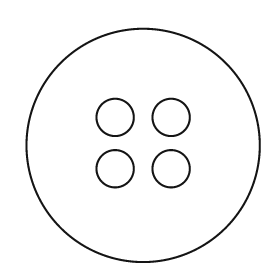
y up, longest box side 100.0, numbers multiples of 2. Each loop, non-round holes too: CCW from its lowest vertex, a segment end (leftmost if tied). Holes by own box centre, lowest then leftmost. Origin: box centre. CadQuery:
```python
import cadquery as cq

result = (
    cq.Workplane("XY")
    .moveTo(0.0, 0.0)
    .circle(50.0)
    .moveTo(-12.0, -10.0)
    .circle(8.0)
    .moveTo(12.0, -10.0)
    .circle(8.0)
    .moveTo(-12.0, 12.0)
    .circle(8.0)
    .moveTo(12.0, 12.0)
    .circle(8.0)
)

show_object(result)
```